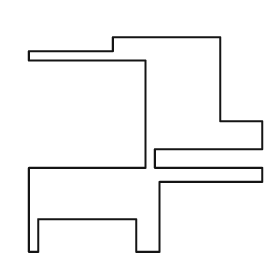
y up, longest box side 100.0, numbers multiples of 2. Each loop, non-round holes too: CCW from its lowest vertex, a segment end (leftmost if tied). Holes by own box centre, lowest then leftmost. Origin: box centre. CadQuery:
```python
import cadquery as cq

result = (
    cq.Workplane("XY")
    .moveTo(-50.0, -46.0)
    .lineTo(-46.0, -46.0)
    .lineTo(-46.0, -32.0)
    .lineTo(-4.0, -32.0)
    .lineTo(-4.0, -46.0)
    .lineTo(6.0, -46.0)
    .lineTo(6.0, -16.0)
    .lineTo(50.0, -16.0)
    .lineTo(50.0, -10.0)
    .lineTo(4.0, -10.0)
    .lineTo(4.0, -2.0)
    .lineTo(50.0, -2.0)
    .lineTo(50.0, 10.0)
    .lineTo(32.0, 10.0)
    .lineTo(32.0, 46.0)
    .lineTo(-14.0, 46.0)
    .lineTo(-14.0, 40.0)
    .lineTo(-50.0, 40.0)
    .lineTo(-50.0, 36.0)
    .lineTo(0.0, 36.0)
    .lineTo(0.0, -10.0)
    .lineTo(-50.0, -10.0)
    .close()
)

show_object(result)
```